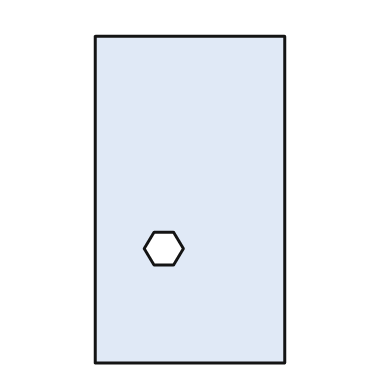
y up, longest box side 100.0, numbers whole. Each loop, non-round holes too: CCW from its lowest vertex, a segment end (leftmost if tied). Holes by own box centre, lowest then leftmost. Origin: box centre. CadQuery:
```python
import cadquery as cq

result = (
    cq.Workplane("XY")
    .moveTo(-29.0, -50.0)
    .lineTo(29.0, -50.0)
    .lineTo(29.0, 50.0)
    .lineTo(-29.0, 50.0)
    .close()
    .moveTo(-11.0, -20.0)
    .lineTo(-5.0, -20.0)
    .lineTo(-2.0, -15.0)
    .lineTo(-5.0, -10.0)
    .lineTo(-11.0, -10.0)
    .lineTo(-14.0, -15.0)
    .close()
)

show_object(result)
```